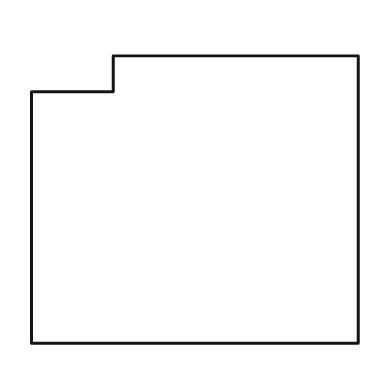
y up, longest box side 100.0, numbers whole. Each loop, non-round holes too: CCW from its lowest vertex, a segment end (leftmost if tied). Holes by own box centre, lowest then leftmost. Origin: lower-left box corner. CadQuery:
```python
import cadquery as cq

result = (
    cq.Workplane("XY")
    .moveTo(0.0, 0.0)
    .lineTo(100.0, 0.0)
    .lineTo(100.0, 88.0)
    .lineTo(25.0, 88.0)
    .lineTo(25.0, 77.0)
    .lineTo(0.0, 77.0)
    .close()
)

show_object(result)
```